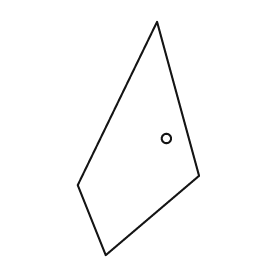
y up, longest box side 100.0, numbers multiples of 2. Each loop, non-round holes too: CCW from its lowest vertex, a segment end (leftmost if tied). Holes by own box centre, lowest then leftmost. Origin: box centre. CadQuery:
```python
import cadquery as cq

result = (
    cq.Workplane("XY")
    .moveTo(-14.0, -50.0)
    .lineTo(26.0, -16.0)
    .lineTo(8.0, 50.0)
    .lineTo(-26.0, -20.0)
    .close()
    .moveTo(12.0, 0.0)
    .circle(2.0)
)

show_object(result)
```